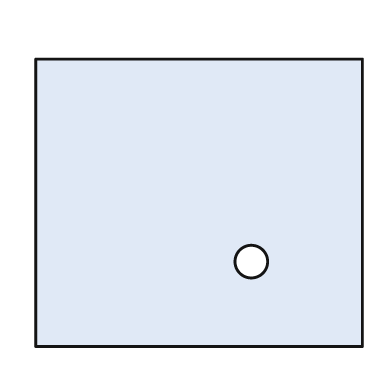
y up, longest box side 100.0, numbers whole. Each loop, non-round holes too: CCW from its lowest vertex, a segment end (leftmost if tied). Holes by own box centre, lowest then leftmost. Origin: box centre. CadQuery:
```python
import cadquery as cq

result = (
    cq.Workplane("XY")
    .moveTo(-50.0, -44.0)
    .lineTo(50.0, -44.0)
    .lineTo(50.0, 44.0)
    .lineTo(-50.0, 44.0)
    .close()
    .moveTo(16.0, -18.0)
    .circle(5.0)
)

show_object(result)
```